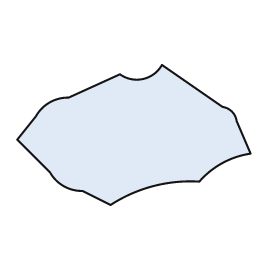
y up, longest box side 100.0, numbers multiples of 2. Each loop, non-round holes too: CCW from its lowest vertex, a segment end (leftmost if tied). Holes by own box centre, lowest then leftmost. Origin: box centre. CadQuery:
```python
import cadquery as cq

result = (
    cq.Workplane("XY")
    .moveTo(-10.0, -30.0)
    .threePointArc((8.0, -22.0), (28.0, -20.0))
    .threePointArc((38.0, -12.0), (50.0, -8.0))
    .lineTo(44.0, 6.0)
    .threePointArc((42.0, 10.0), (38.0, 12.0))
    .lineTo(12.0, 30.0)
    .threePointArc((4.0, 24.0), (-6.0, 26.0))
    .lineTo(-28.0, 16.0)
    .threePointArc((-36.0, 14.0), (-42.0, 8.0))
    .lineTo(-50.0, -2.0)
    .lineTo(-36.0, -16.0)
    .threePointArc((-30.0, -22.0), (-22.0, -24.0))
    .close()
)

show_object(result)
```